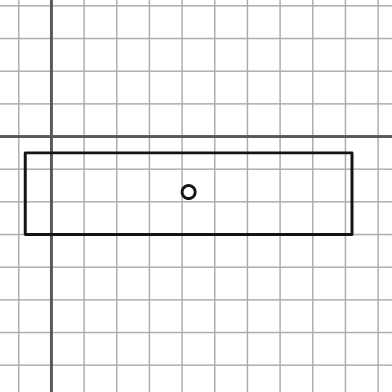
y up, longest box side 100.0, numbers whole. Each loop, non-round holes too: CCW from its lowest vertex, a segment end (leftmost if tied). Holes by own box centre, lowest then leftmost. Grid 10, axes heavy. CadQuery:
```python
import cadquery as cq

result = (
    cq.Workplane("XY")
    .moveTo(-8.0, -30.0)
    .lineTo(92.0, -30.0)
    .lineTo(92.0, -5.0)
    .lineTo(-8.0, -5.0)
    .close()
    .moveTo(42.0, -17.0)
    .circle(2.0)
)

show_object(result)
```